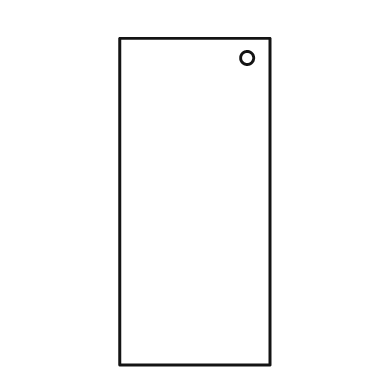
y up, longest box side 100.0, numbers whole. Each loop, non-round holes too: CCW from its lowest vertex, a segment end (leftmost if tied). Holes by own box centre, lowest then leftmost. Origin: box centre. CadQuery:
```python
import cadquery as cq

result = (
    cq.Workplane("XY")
    .moveTo(-23.0, -50.0)
    .lineTo(23.0, -50.0)
    .lineTo(23.0, 50.0)
    .lineTo(-23.0, 50.0)
    .close()
    .moveTo(16.0, 44.0)
    .circle(2.0)
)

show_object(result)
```